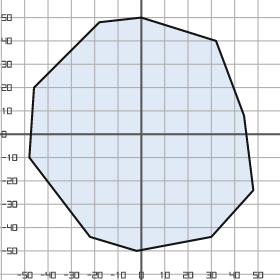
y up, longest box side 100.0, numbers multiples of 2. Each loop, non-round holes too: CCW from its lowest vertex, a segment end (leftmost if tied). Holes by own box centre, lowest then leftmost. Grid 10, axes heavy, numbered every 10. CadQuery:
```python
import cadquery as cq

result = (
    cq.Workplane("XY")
    .moveTo(-2.0, -50.0)
    .lineTo(30.0, -44.0)
    .lineTo(48.0, -24.0)
    .lineTo(44.0, 8.0)
    .lineTo(32.0, 40.0)
    .lineTo(0.0, 50.0)
    .lineTo(-18.0, 48.0)
    .lineTo(-46.0, 20.0)
    .lineTo(-48.0, -10.0)
    .lineTo(-22.0, -44.0)
    .close()
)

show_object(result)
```